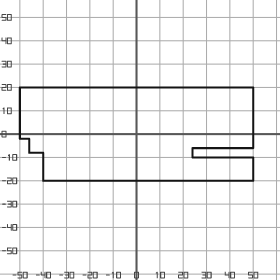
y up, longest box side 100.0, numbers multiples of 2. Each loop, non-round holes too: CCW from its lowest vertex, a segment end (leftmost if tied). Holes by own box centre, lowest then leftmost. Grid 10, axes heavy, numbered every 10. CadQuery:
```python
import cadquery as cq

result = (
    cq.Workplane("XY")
    .moveTo(-40.0, -20.0)
    .lineTo(50.0, -20.0)
    .lineTo(50.0, -10.0)
    .lineTo(24.0, -10.0)
    .lineTo(24.0, -6.0)
    .lineTo(50.0, -6.0)
    .lineTo(50.0, 20.0)
    .lineTo(-50.0, 20.0)
    .lineTo(-50.0, -2.0)
    .lineTo(-46.0, -2.0)
    .lineTo(-46.0, -8.0)
    .lineTo(-40.0, -8.0)
    .close()
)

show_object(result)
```